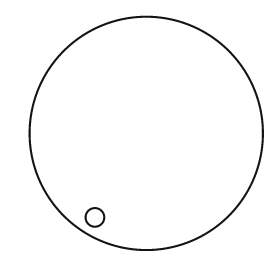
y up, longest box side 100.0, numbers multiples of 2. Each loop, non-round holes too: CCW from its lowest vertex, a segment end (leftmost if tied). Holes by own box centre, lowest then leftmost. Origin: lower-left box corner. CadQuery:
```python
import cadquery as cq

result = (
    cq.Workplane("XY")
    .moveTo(50.0, 50.0)
    .circle(50.0)
    .moveTo(28.0, 14.0)
    .circle(4.0)
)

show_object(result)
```